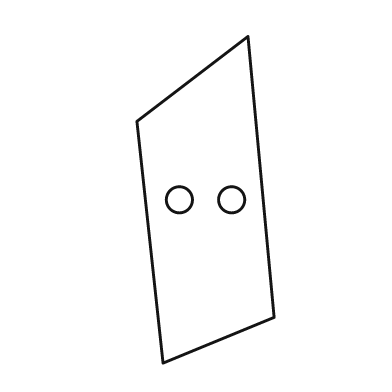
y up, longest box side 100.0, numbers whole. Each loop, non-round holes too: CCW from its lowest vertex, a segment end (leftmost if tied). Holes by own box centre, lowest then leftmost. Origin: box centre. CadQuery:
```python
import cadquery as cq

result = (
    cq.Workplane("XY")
    .moveTo(-13.0, -50.0)
    .lineTo(21.0, -36.0)
    .lineTo(13.0, 50.0)
    .lineTo(-21.0, 24.0)
    .close()
    .moveTo(-8.0, 0.0)
    .circle(4.0)
    .moveTo(8.0, 0.0)
    .circle(4.0)
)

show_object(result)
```